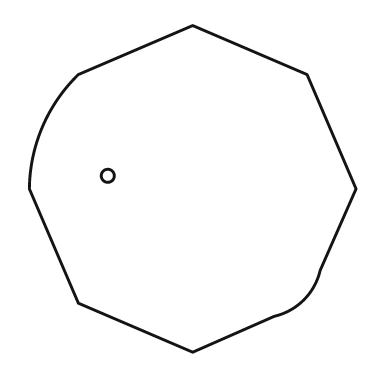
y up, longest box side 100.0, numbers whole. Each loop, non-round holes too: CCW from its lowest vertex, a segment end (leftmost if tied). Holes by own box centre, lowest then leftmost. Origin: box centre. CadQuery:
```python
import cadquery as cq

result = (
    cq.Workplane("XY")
    .moveTo(0.0, -50.0)
    .lineTo(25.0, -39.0)
    .threePointArc((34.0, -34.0), (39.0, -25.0))
    .lineTo(50.0, 0.0)
    .lineTo(35.0, 35.0)
    .lineTo(0.0, 50.0)
    .lineTo(-35.0, 35.0)
    .threePointArc((-46.0, 19.0), (-50.0, 0.0))
    .lineTo(-35.0, -35.0)
    .close()
    .moveTo(-26.0, 4.0)
    .circle(2.0)
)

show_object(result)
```